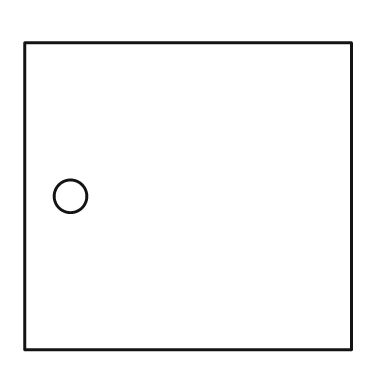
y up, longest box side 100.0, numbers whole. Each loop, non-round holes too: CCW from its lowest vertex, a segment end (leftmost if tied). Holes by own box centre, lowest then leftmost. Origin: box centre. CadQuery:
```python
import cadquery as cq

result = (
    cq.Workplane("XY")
    .moveTo(-50.0, -47.0)
    .lineTo(50.0, -47.0)
    .lineTo(50.0, 47.0)
    .lineTo(-50.0, 47.0)
    .close()
    .moveTo(-36.0, 0.0)
    .circle(5.0)
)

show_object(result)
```